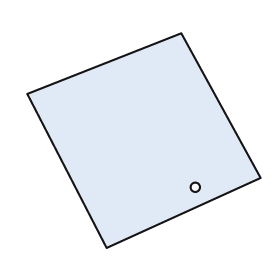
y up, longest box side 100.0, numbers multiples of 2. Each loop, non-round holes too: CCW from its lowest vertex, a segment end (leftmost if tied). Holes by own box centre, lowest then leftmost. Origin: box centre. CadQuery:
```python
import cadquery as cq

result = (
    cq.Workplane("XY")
    .moveTo(-16.0, -46.0)
    .lineTo(50.0, -16.0)
    .lineTo(16.0, 46.0)
    .lineTo(-50.0, 20.0)
    .close()
    .moveTo(22.0, -20.0)
    .circle(2.0)
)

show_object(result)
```